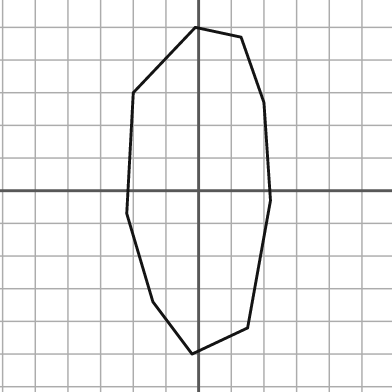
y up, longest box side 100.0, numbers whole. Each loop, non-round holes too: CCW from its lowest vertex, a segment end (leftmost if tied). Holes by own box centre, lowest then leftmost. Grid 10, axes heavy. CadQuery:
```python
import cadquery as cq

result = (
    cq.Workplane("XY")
    .moveTo(-2.0, -50.0)
    .lineTo(15.0, -42.0)
    .lineTo(22.0, -3.0)
    .lineTo(20.0, 27.0)
    .lineTo(13.0, 47.0)
    .lineTo(-1.0, 50.0)
    .lineTo(-20.0, 30.0)
    .lineTo(-22.0, -7.0)
    .lineTo(-14.0, -34.0)
    .close()
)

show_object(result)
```